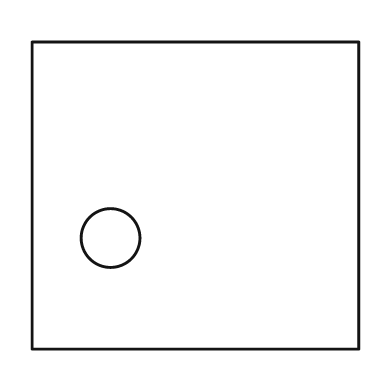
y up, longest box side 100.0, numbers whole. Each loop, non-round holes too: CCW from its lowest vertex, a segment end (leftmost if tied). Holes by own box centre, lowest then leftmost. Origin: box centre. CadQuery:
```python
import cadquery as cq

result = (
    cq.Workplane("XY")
    .moveTo(-50.0, -47.0)
    .lineTo(50.0, -47.0)
    .lineTo(50.0, 47.0)
    .lineTo(-50.0, 47.0)
    .close()
    .moveTo(-26.0, -13.0)
    .circle(9.0)
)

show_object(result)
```